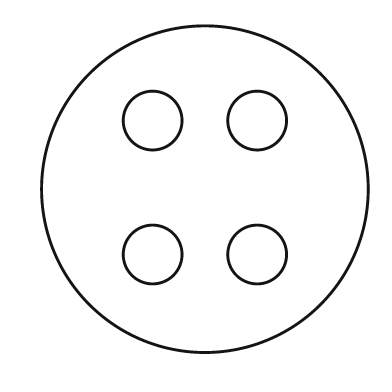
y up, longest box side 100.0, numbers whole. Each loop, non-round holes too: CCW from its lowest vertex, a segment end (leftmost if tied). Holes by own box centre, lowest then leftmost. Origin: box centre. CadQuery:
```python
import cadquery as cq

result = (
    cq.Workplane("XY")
    .moveTo(0.0, 0.0)
    .circle(50.0)
    .moveTo(-16.0, -20.0)
    .circle(9.0)
    .moveTo(16.0, -20.0)
    .circle(9.0)
    .moveTo(-16.0, 21.0)
    .circle(9.0)
    .moveTo(16.0, 21.0)
    .circle(9.0)
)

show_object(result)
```